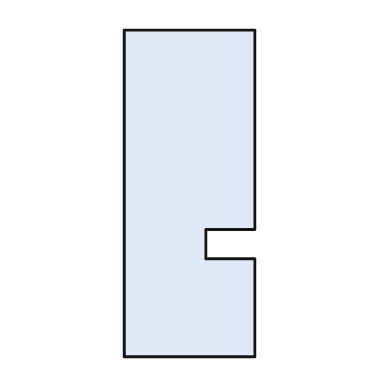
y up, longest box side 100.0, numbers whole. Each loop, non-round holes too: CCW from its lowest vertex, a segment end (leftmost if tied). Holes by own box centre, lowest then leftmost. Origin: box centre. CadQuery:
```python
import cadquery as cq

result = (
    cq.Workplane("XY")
    .moveTo(-20.0, -50.0)
    .lineTo(20.0, -50.0)
    .lineTo(20.0, -20.0)
    .lineTo(5.0, -20.0)
    .lineTo(5.0, -11.0)
    .lineTo(20.0, -11.0)
    .lineTo(20.0, 50.0)
    .lineTo(-20.0, 50.0)
    .close()
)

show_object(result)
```